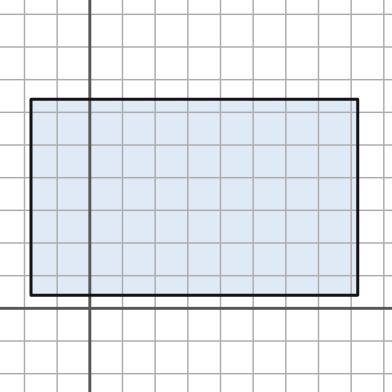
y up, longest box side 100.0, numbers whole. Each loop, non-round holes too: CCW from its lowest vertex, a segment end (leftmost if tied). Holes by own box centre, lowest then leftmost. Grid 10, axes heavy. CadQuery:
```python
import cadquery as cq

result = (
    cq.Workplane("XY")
    .moveTo(-18.0, 4.0)
    .lineTo(82.0, 4.0)
    .lineTo(82.0, 64.0)
    .lineTo(-18.0, 64.0)
    .close()
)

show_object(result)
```